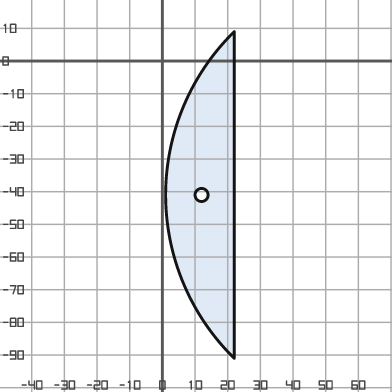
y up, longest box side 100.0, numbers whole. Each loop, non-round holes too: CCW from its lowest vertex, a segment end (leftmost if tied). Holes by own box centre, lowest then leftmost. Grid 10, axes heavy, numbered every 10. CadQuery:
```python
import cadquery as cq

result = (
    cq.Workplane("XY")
    .moveTo(22.0, -91.0)
    .lineTo(22.0, 9.0)
    .threePointArc((1.0, -41.0), (22.0, -91.0))
    .close()
    .moveTo(12.0, -41.0)
    .circle(2.0)
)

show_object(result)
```